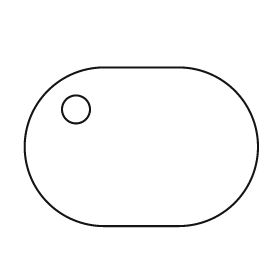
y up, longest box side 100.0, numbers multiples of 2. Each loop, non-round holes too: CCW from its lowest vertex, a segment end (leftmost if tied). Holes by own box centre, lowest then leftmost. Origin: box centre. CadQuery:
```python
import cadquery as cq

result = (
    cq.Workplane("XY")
    .moveTo(-16.0, -34.0)
    .lineTo(16.0, -34.0)
    .threePointArc((50.0, 0.0), (16.0, 34.0))
    .lineTo(-16.0, 34.0)
    .threePointArc((-50.0, 0.0), (-16.0, -34.0))
    .close()
    .moveTo(-28.0, 16.0)
    .circle(6.0)
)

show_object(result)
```